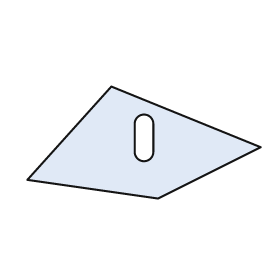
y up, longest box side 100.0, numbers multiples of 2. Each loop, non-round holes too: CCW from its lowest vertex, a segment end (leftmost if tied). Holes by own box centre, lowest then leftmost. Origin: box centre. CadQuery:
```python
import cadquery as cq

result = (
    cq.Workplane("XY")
    .moveTo(6.0, -24.0)
    .lineTo(50.0, -2.0)
    .lineTo(-14.0, 24.0)
    .lineTo(-50.0, -16.0)
    .close()
    .moveTo(-4.0, -4.0)
    .threePointArc((0.0, -8.0), (4.0, -4.0))
    .lineTo(4.0, 8.0)
    .threePointArc((0.0, 12.0), (-4.0, 8.0))
    .close()
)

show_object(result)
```